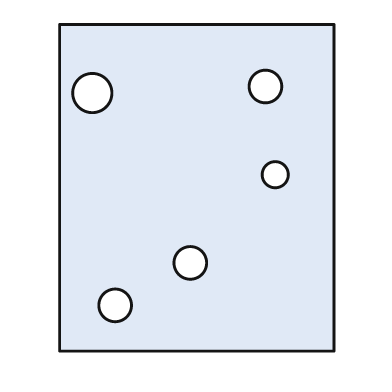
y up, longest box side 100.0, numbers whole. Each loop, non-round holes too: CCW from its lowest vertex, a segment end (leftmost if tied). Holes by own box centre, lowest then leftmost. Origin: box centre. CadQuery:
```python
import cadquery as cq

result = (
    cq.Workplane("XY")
    .moveTo(-42.0, -50.0)
    .lineTo(42.0, -50.0)
    .lineTo(42.0, 50.0)
    .lineTo(-42.0, 50.0)
    .close()
    .moveTo(-25.0, -36.0)
    .circle(5.0)
    .moveTo(-2.0, -23.0)
    .circle(5.0)
    .moveTo(24.0, 4.0)
    .circle(4.0)
    .moveTo(-32.0, 29.0)
    .circle(6.0)
    .moveTo(21.0, 31.0)
    .circle(5.0)
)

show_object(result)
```